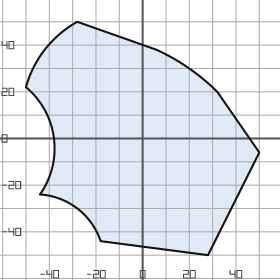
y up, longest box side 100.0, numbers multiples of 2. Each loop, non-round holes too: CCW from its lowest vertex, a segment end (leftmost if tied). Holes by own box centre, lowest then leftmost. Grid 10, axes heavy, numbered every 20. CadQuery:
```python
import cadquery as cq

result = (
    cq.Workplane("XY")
    .moveTo(28.0, -50.0)
    .lineTo(50.0, -6.0)
    .lineTo(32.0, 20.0)
    .threePointArc((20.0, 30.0), (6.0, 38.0))
    .lineTo(-28.0, 50.0)
    .threePointArc((-42.0, 38.0), (-50.0, 22.0))
    .threePointArc((-38.0, 0.0), (-44.0, -24.0))
    .threePointArc((-28.0, -30.0), (-18.0, -44.0))
    .close()
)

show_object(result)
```